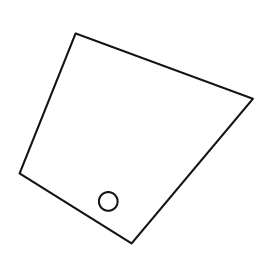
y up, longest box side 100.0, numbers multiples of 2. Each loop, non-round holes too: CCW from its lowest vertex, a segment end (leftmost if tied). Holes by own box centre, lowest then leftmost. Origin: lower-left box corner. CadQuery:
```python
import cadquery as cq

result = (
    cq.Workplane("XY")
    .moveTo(48.0, 0.0)
    .lineTo(100.0, 62.0)
    .lineTo(24.0, 90.0)
    .lineTo(0.0, 30.0)
    .close()
    .moveTo(38.0, 18.0)
    .circle(4.0)
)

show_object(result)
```